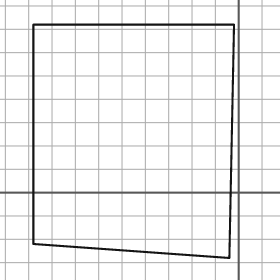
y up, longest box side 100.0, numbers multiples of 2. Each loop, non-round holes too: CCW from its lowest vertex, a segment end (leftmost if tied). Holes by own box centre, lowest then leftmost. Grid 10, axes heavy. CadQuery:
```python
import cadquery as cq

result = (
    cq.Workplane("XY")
    .moveTo(-4.0, -28.0)
    .lineTo(-2.0, 72.0)
    .lineTo(-88.0, 72.0)
    .lineTo(-88.0, -22.0)
    .close()
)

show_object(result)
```